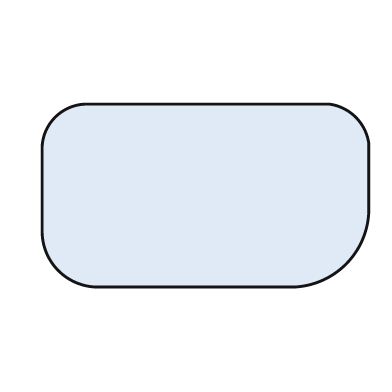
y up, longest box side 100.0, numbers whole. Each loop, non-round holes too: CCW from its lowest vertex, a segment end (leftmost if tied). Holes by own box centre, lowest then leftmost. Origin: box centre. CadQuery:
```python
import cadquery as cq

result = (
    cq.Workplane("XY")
    .moveTo(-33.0, -28.0)
    .lineTo(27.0, -28.0)
    .threePointArc((43.0, -21.0), (50.0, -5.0))
    .lineTo(50.0, 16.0)
    .threePointArc((46.0, 24.0), (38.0, 28.0))
    .lineTo(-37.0, 28.0)
    .threePointArc((-46.0, 24.0), (-50.0, 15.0))
    .lineTo(-50.0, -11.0)
    .threePointArc((-45.0, -23.0), (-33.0, -28.0))
    .close()
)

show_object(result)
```